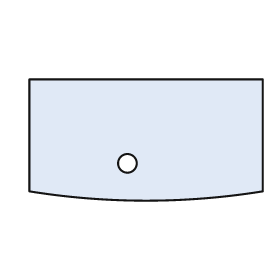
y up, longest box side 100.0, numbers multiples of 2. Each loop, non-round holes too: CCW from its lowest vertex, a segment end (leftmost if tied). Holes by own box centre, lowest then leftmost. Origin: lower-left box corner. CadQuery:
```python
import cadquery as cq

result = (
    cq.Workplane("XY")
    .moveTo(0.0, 4.0)
    .threePointArc((50.0, 0.0), (100.0, 4.0))
    .lineTo(100.0, 52.0)
    .lineTo(0.0, 52.0)
    .close()
    .moveTo(42.0, 16.0)
    .circle(4.0)
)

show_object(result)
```